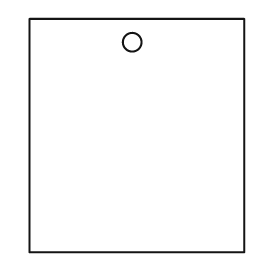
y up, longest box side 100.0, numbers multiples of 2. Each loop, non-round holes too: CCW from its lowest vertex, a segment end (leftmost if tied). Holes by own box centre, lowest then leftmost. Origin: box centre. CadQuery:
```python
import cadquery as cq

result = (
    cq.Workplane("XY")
    .moveTo(-46.0, -50.0)
    .lineTo(46.0, -50.0)
    .lineTo(46.0, 50.0)
    .lineTo(-46.0, 50.0)
    .close()
    .moveTo(-2.0, 40.0)
    .circle(4.0)
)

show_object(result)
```